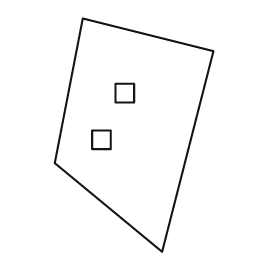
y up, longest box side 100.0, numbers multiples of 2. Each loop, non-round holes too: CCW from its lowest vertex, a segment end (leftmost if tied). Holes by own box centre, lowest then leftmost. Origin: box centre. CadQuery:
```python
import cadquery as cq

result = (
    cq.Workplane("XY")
    .moveTo(12.0, -50.0)
    .lineTo(34.0, 36.0)
    .lineTo(-22.0, 50.0)
    .lineTo(-34.0, -12.0)
    .close()
    .moveTo(-18.0, -6.0)
    .lineTo(-10.0, -6.0)
    .lineTo(-10.0, 2.0)
    .lineTo(-18.0, 2.0)
    .close()
    .moveTo(-8.0, 14.0)
    .lineTo(0.0, 14.0)
    .lineTo(0.0, 22.0)
    .lineTo(-8.0, 22.0)
    .close()
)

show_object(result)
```